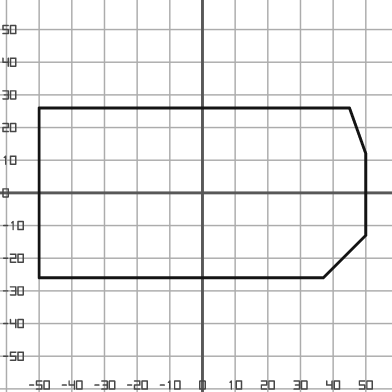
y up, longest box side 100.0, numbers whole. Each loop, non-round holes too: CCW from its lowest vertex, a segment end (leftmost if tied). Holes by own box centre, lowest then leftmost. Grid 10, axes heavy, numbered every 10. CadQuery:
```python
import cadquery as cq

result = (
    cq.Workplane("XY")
    .moveTo(-50.0, -26.0)
    .lineTo(37.0, -26.0)
    .lineTo(50.0, -13.0)
    .lineTo(50.0, 12.0)
    .lineTo(45.0, 26.0)
    .lineTo(-50.0, 26.0)
    .close()
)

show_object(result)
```